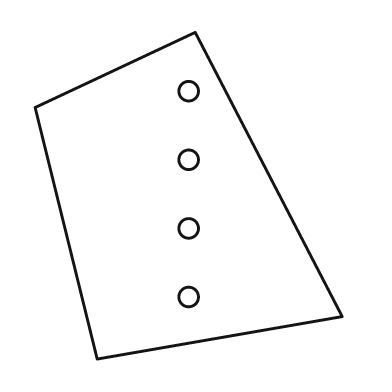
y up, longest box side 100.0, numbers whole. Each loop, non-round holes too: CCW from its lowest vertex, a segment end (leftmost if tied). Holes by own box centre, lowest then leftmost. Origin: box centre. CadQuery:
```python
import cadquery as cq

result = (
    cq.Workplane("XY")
    .moveTo(-28.0, -50.0)
    .lineTo(47.0, -37.0)
    .lineTo(2.0, 50.0)
    .lineTo(-47.0, 27.0)
    .close()
    .moveTo(0.0, -31.0)
    .circle(3.0)
    .moveTo(0.0, -10.0)
    .circle(3.0)
    .moveTo(0.0, 11.0)
    .circle(3.0)
    .moveTo(0.0, 32.0)
    .circle(3.0)
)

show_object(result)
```